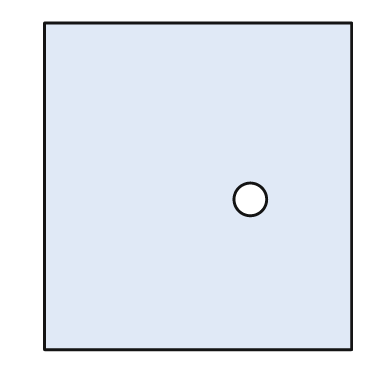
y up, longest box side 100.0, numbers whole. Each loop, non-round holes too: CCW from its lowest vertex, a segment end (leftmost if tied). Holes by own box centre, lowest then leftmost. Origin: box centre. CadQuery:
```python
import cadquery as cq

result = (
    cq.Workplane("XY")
    .moveTo(-47.0, -50.0)
    .lineTo(47.0, -50.0)
    .lineTo(47.0, 50.0)
    .lineTo(-47.0, 50.0)
    .close()
    .moveTo(16.0, -4.0)
    .circle(5.0)
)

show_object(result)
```